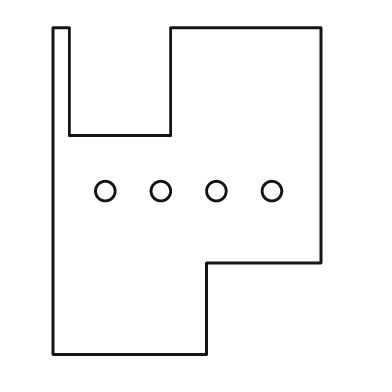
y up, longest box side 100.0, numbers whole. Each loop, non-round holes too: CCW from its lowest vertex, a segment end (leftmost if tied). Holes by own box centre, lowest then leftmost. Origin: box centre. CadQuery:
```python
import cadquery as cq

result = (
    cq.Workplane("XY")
    .moveTo(-41.0, -50.0)
    .lineTo(6.0, -50.0)
    .lineTo(6.0, -22.0)
    .lineTo(41.0, -22.0)
    .lineTo(41.0, 50.0)
    .lineTo(-5.0, 50.0)
    .lineTo(-5.0, 17.0)
    .lineTo(-36.0, 17.0)
    .lineTo(-36.0, 50.0)
    .lineTo(-41.0, 50.0)
    .close()
    .moveTo(-25.0, 0.0)
    .circle(3.0)
    .moveTo(-8.0, 0.0)
    .circle(3.0)
    .moveTo(9.0, 0.0)
    .circle(3.0)
    .moveTo(26.0, 0.0)
    .circle(3.0)
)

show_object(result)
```